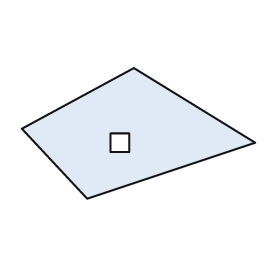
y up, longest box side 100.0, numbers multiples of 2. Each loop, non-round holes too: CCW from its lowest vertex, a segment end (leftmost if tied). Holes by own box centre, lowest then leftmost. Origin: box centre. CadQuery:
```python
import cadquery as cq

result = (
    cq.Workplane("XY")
    .moveTo(-22.0, -28.0)
    .lineTo(50.0, -4.0)
    .lineTo(-2.0, 28.0)
    .lineTo(-50.0, 2.0)
    .close()
    .moveTo(-12.0, -8.0)
    .lineTo(-4.0, -8.0)
    .lineTo(-4.0, 0.0)
    .lineTo(-12.0, 0.0)
    .close()
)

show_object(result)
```